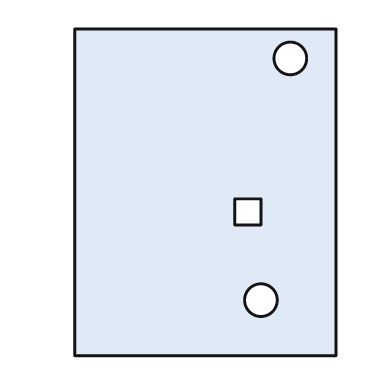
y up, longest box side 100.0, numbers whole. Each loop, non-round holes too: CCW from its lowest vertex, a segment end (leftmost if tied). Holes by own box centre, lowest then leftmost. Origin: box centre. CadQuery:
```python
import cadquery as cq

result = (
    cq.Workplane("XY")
    .moveTo(-40.0, -50.0)
    .lineTo(40.0, -50.0)
    .lineTo(40.0, 50.0)
    .lineTo(-40.0, 50.0)
    .close()
    .moveTo(17.0, -33.0)
    .circle(5.0)
    .moveTo(9.0, -10.0)
    .lineTo(17.0, -10.0)
    .lineTo(17.0, -2.0)
    .lineTo(9.0, -2.0)
    .close()
    .moveTo(26.0, 41.0)
    .circle(5.0)
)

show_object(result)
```